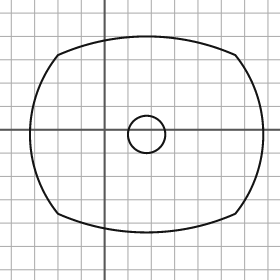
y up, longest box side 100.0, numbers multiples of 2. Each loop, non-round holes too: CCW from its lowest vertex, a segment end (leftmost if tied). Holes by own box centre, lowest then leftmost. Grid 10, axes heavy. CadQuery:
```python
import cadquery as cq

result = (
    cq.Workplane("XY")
    .moveTo(-20.0, -36.0)
    .threePointArc((18.0, -44.0), (56.0, -36.0))
    .threePointArc((68.0, -2.0), (56.0, 32.0))
    .threePointArc((18.0, 40.0), (-20.0, 32.0))
    .threePointArc((-32.0, -2.0), (-20.0, -36.0))
    .close()
    .moveTo(18.0, -2.0)
    .circle(8.0)
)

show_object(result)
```